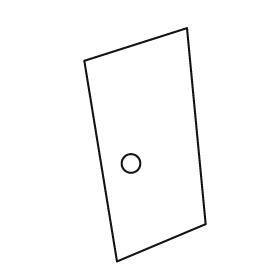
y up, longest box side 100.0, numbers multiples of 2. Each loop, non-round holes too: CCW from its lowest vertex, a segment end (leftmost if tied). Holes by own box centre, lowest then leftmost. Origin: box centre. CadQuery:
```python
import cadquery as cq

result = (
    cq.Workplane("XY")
    .moveTo(-12.0, -50.0)
    .lineTo(26.0, -34.0)
    .lineTo(18.0, 50.0)
    .lineTo(-26.0, 36.0)
    .close()
    .moveTo(-6.0, -8.0)
    .circle(4.0)
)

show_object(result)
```